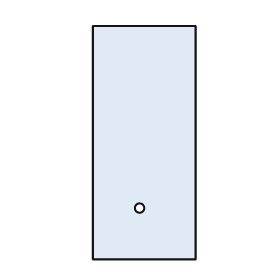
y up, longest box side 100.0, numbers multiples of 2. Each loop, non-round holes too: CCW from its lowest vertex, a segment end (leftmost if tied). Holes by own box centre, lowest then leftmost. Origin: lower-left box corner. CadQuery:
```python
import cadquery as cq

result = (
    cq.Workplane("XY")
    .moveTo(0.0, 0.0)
    .lineTo(44.0, 0.0)
    .lineTo(44.0, 100.0)
    .lineTo(0.0, 100.0)
    .close()
    .moveTo(20.0, 22.0)
    .circle(2.0)
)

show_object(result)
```